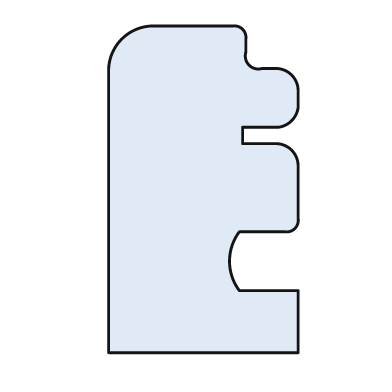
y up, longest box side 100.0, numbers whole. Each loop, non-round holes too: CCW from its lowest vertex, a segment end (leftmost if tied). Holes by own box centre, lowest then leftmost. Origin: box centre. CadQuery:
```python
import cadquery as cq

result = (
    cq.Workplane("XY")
    .moveTo(-29.0, -50.0)
    .lineTo(29.0, -50.0)
    .lineTo(29.0, -31.0)
    .lineTo(11.0, -31.0)
    .threePointArc((8.0, -22.0), (11.0, -13.0))
    .lineTo(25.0, -13.0)
    .threePointArc((28.0, -12.0), (29.0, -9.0))
    .lineTo(29.0, 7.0)
    .threePointArc((27.0, 12.0), (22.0, 14.0))
    .lineTo(12.0, 14.0)
    .lineTo(12.0, 19.0)
    .lineTo(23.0, 19.0)
    .threePointArc((27.0, 21.0), (29.0, 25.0))
    .lineTo(29.0, 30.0)
    .threePointArc((27.0, 35.0), (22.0, 37.0))
    .lineTo(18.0, 37.0)
    .threePointArc((14.0, 38.0), (13.0, 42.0))
    .lineTo(13.0, 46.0)
    .threePointArc((12.0, 49.0), (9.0, 50.0))
    .lineTo(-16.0, 50.0)
    .threePointArc((-25.0, 46.0), (-29.0, 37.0))
    .close()
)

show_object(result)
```